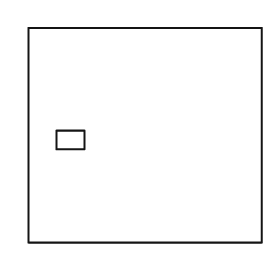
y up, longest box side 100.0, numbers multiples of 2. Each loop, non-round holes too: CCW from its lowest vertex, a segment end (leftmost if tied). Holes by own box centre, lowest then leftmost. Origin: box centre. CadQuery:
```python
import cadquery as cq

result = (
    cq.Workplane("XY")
    .moveTo(-50.0, -46.0)
    .lineTo(50.0, -46.0)
    .lineTo(50.0, 46.0)
    .lineTo(-50.0, 46.0)
    .close()
    .moveTo(-38.0, -6.0)
    .lineTo(-26.0, -6.0)
    .lineTo(-26.0, 2.0)
    .lineTo(-38.0, 2.0)
    .close()
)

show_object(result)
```